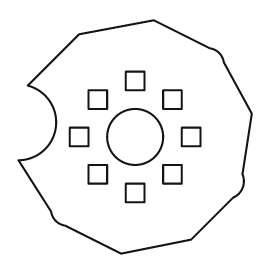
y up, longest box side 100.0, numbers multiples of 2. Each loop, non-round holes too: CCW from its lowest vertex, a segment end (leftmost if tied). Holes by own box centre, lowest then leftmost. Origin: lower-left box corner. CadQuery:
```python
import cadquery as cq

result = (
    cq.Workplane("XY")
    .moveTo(44.0, 0.0)
    .lineTo(74.0, 6.0)
    .lineTo(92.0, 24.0)
    .threePointArc((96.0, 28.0), (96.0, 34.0))
    .lineTo(100.0, 60.0)
    .lineTo(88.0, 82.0)
    .threePointArc((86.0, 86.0), (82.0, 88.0))
    .lineTo(58.0, 100.0)
    .lineTo(26.0, 94.0)
    .lineTo(4.0, 72.0)
    .threePointArc((16.0, 54.0), (0.0, 40.0))
    .lineTo(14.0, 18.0)
    .threePointArc((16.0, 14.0), (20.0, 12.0))
    .close()
    .moveTo(46.0, 22.0)
    .lineTo(54.0, 22.0)
    .lineTo(54.0, 30.0)
    .lineTo(46.0, 30.0)
    .close()
    .moveTo(30.0, 30.0)
    .lineTo(38.0, 30.0)
    .lineTo(38.0, 38.0)
    .lineTo(30.0, 38.0)
    .close()
    .moveTo(62.0, 30.0)
    .lineTo(70.0, 30.0)
    .lineTo(70.0, 38.0)
    .lineTo(62.0, 38.0)
    .close()
    .moveTo(22.0, 46.0)
    .lineTo(30.0, 46.0)
    .lineTo(30.0, 54.0)
    .lineTo(22.0, 54.0)
    .close()
    .moveTo(50.0, 50.0)
    .circle(12.0)
    .moveTo(70.0, 46.0)
    .lineTo(78.0, 46.0)
    .lineTo(78.0, 54.0)
    .lineTo(70.0, 54.0)
    .close()
    .moveTo(30.0, 62.0)
    .lineTo(38.0, 62.0)
    .lineTo(38.0, 70.0)
    .lineTo(30.0, 70.0)
    .close()
    .moveTo(62.0, 62.0)
    .lineTo(70.0, 62.0)
    .lineTo(70.0, 70.0)
    .lineTo(62.0, 70.0)
    .close()
    .moveTo(46.0, 70.0)
    .lineTo(54.0, 70.0)
    .lineTo(54.0, 78.0)
    .lineTo(46.0, 78.0)
    .close()
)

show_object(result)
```